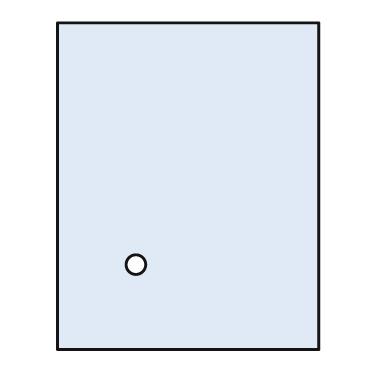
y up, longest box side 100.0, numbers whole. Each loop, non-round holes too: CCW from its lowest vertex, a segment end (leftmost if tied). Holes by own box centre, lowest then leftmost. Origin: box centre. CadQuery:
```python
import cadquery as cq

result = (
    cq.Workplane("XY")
    .moveTo(-40.0, -50.0)
    .lineTo(40.0, -50.0)
    .lineTo(40.0, 50.0)
    .lineTo(-40.0, 50.0)
    .close()
    .moveTo(-16.0, -24.0)
    .circle(3.0)
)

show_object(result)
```